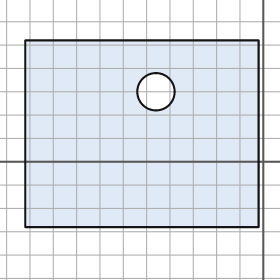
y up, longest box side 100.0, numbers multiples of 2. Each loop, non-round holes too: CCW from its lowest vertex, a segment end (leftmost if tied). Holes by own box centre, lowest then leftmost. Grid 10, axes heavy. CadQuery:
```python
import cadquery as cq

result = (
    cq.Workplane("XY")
    .moveTo(-102.0, -28.0)
    .lineTo(-2.0, -28.0)
    .lineTo(-2.0, 52.0)
    .lineTo(-102.0, 52.0)
    .close()
    .moveTo(-46.0, 30.0)
    .circle(8.0)
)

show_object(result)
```